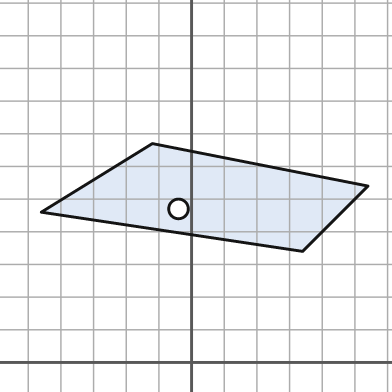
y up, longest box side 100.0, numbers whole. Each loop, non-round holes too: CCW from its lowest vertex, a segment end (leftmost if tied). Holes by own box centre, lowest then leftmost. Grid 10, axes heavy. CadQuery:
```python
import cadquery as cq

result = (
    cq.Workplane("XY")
    .moveTo(34.0, 34.0)
    .lineTo(54.0, 54.0)
    .lineTo(-12.0, 67.0)
    .lineTo(-46.0, 46.0)
    .close()
    .moveTo(-4.0, 47.0)
    .circle(3.0)
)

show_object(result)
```